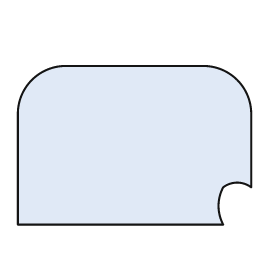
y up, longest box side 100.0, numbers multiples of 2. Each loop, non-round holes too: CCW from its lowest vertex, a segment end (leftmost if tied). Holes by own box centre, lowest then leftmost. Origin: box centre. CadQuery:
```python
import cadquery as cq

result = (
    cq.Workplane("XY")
    .moveTo(-50.0, -34.0)
    .lineTo(38.0, -34.0)
    .threePointArc((36.0, -26.0), (38.0, -18.0))
    .threePointArc((44.0, -16.0), (50.0, -18.0))
    .lineTo(50.0, 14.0)
    .threePointArc((44.0, 28.0), (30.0, 34.0))
    .lineTo(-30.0, 34.0)
    .threePointArc((-44.0, 28.0), (-50.0, 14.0))
    .close()
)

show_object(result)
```